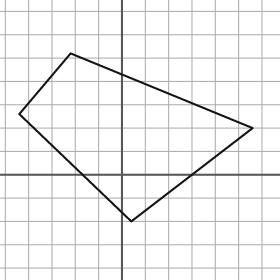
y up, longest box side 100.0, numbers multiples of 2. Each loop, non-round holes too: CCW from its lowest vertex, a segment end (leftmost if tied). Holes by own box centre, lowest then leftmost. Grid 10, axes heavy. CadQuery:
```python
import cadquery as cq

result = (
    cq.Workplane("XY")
    .moveTo(4.0, -20.0)
    .lineTo(56.0, 20.0)
    .lineTo(-22.0, 52.0)
    .lineTo(-44.0, 26.0)
    .close()
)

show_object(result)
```